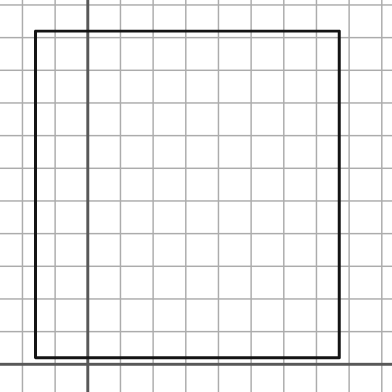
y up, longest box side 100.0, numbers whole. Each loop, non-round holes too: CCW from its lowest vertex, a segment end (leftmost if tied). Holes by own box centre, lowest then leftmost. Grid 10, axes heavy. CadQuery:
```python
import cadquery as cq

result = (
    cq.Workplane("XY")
    .moveTo(-16.0, 2.0)
    .lineTo(77.0, 2.0)
    .lineTo(77.0, 102.0)
    .lineTo(-16.0, 102.0)
    .close()
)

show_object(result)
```